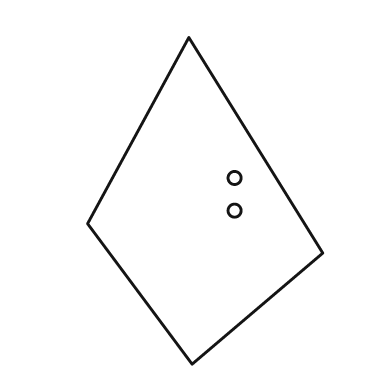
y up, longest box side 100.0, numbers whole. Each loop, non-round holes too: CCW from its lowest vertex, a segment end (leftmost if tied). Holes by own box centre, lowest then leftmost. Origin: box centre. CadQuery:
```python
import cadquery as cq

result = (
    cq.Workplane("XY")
    .moveTo(-4.0, -50.0)
    .lineTo(36.0, -16.0)
    .lineTo(-5.0, 50.0)
    .lineTo(-36.0, -7.0)
    .close()
    .moveTo(9.0, -3.0)
    .circle(2.0)
    .moveTo(9.0, 7.0)
    .circle(2.0)
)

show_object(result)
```